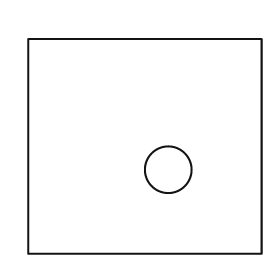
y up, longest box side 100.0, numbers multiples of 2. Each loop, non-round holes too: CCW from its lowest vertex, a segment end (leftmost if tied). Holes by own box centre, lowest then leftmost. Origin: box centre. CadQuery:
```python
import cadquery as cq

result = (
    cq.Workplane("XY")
    .moveTo(-50.0, -46.0)
    .lineTo(50.0, -46.0)
    .lineTo(50.0, 46.0)
    .lineTo(-50.0, 46.0)
    .close()
    .moveTo(10.0, -10.0)
    .circle(10.0)
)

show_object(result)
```